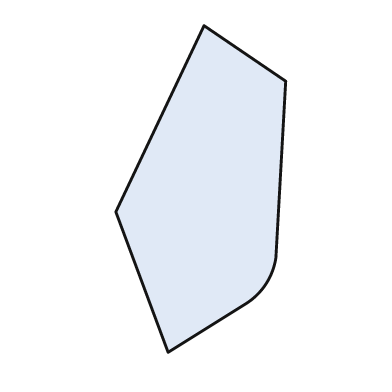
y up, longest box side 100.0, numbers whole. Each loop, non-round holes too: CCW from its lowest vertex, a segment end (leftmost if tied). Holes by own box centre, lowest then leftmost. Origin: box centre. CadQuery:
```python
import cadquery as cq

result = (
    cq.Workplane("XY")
    .moveTo(-10.0, -50.0)
    .lineTo(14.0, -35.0)
    .threePointArc((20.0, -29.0), (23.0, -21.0))
    .lineTo(26.0, 33.0)
    .lineTo(1.0, 50.0)
    .lineTo(-26.0, -7.0)
    .close()
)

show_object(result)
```